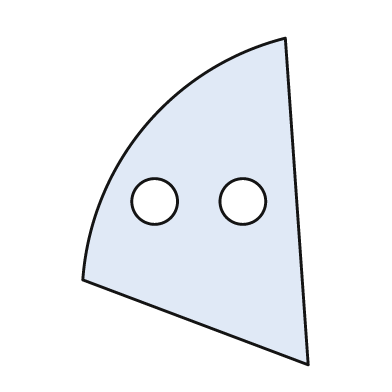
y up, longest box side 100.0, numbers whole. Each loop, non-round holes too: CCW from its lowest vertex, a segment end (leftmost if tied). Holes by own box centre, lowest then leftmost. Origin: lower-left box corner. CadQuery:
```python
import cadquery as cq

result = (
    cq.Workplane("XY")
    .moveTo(69.0, 0.0)
    .lineTo(62.0, 100.0)
    .threePointArc((19.0, 73.0), (0.0, 26.0))
    .close()
    .moveTo(22.0, 50.0)
    .circle(7.0)
    .moveTo(49.0, 50.0)
    .circle(7.0)
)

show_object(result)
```